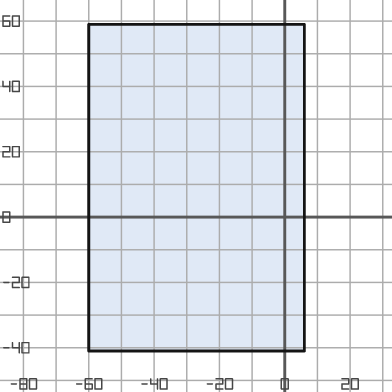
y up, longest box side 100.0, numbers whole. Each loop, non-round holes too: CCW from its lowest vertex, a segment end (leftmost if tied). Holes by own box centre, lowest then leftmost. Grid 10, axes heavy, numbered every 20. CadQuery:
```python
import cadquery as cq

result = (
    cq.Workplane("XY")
    .moveTo(-60.0, -41.0)
    .lineTo(6.0, -41.0)
    .lineTo(6.0, 59.0)
    .lineTo(-60.0, 59.0)
    .close()
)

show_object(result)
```